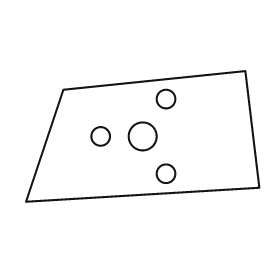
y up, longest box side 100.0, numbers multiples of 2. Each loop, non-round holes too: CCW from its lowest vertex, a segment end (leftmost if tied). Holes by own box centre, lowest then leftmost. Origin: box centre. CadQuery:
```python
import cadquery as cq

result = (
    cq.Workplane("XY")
    .moveTo(-50.0, -28.0)
    .lineTo(50.0, -22.0)
    .lineTo(44.0, 28.0)
    .lineTo(-34.0, 20.0)
    .close()
    .moveTo(10.0, -16.0)
    .circle(4.0)
    .moveTo(-18.0, 0.0)
    .circle(4.0)
    .moveTo(0.0, 0.0)
    .circle(6.0)
    .moveTo(10.0, 16.0)
    .circle(4.0)
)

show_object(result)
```